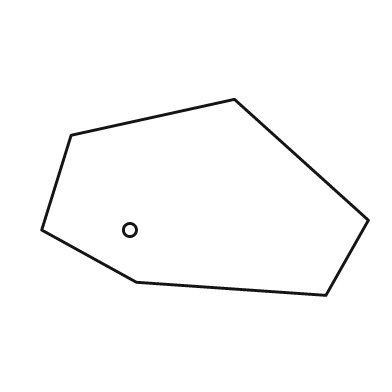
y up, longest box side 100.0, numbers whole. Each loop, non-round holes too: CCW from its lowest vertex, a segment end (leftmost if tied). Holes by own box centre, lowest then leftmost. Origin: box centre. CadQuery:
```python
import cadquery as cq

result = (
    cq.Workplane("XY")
    .moveTo(37.0, -30.0)
    .lineTo(50.0, -7.0)
    .lineTo(9.0, 30.0)
    .lineTo(-41.0, 19.0)
    .lineTo(-50.0, -10.0)
    .lineTo(-21.0, -26.0)
    .close()
    .moveTo(-23.0, -10.0)
    .circle(2.0)
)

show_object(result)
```